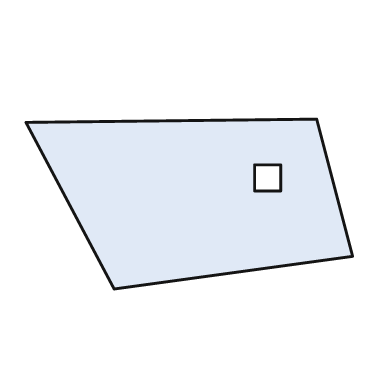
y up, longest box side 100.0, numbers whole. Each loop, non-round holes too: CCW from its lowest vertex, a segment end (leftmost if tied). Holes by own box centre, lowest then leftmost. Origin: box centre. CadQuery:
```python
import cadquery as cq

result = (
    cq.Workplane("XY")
    .moveTo(-23.0, -26.0)
    .lineTo(50.0, -16.0)
    .lineTo(39.0, 26.0)
    .lineTo(-50.0, 25.0)
    .close()
    .moveTo(20.0, 4.0)
    .lineTo(28.0, 4.0)
    .lineTo(28.0, 12.0)
    .lineTo(20.0, 12.0)
    .close()
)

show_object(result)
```